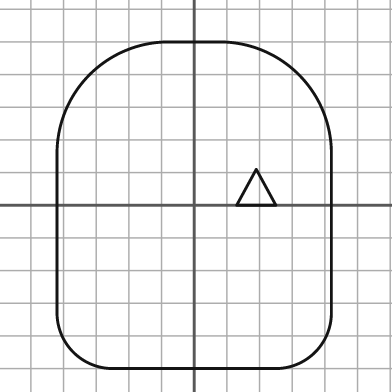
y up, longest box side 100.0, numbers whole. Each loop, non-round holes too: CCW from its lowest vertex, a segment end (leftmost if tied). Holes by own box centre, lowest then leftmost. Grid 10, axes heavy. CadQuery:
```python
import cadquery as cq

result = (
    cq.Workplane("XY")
    .moveTo(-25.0, -50.0)
    .lineTo(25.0, -50.0)
    .threePointArc((37.0, -45.0), (42.0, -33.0))
    .lineTo(42.0, 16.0)
    .threePointArc((32.0, 40.0), (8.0, 50.0))
    .lineTo(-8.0, 50.0)
    .threePointArc((-32.0, 40.0), (-42.0, 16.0))
    .lineTo(-42.0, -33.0)
    .threePointArc((-37.0, -45.0), (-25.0, -50.0))
    .close()
    .moveTo(13.0, 0.0)
    .lineTo(25.0, 0.0)
    .lineTo(19.0, 11.0)
    .close()
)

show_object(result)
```